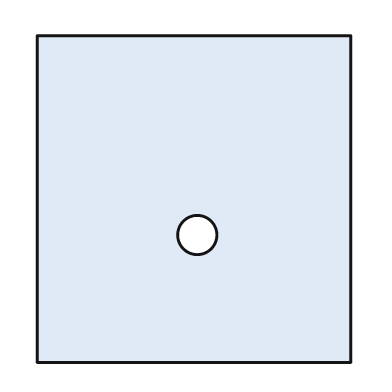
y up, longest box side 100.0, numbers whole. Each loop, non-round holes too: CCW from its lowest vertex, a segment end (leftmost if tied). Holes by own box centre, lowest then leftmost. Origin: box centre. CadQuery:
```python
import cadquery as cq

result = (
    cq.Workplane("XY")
    .moveTo(-48.0, -50.0)
    .lineTo(48.0, -50.0)
    .lineTo(48.0, 50.0)
    .lineTo(-48.0, 50.0)
    .close()
    .moveTo(1.0, -11.0)
    .circle(6.0)
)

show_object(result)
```